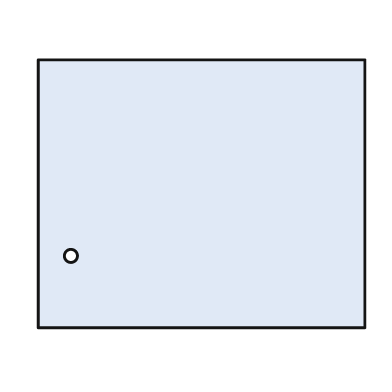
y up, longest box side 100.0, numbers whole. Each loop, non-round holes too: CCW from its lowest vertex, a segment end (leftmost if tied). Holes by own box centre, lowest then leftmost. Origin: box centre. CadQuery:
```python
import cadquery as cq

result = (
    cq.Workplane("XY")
    .moveTo(-50.0, -41.0)
    .lineTo(50.0, -41.0)
    .lineTo(50.0, 41.0)
    .lineTo(-50.0, 41.0)
    .close()
    .moveTo(-40.0, -19.0)
    .circle(2.0)
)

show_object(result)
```